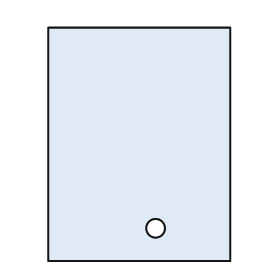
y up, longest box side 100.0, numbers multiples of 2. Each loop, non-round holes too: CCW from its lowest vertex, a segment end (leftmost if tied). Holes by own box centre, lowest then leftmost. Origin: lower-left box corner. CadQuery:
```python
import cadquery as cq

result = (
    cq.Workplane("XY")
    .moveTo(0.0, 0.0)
    .lineTo(78.0, 0.0)
    .lineTo(78.0, 100.0)
    .lineTo(0.0, 100.0)
    .close()
    .moveTo(46.0, 14.0)
    .circle(4.0)
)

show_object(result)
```